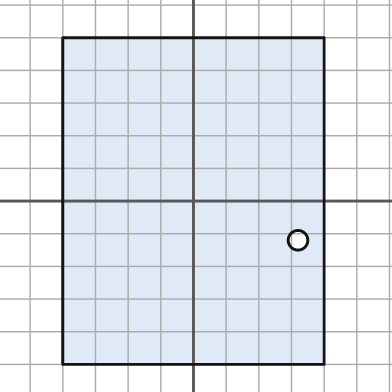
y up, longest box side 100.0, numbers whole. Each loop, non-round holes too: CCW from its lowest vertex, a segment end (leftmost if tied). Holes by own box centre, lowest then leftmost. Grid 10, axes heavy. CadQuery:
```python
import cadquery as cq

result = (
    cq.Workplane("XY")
    .moveTo(-40.0, -50.0)
    .lineTo(40.0, -50.0)
    .lineTo(40.0, 50.0)
    .lineTo(-40.0, 50.0)
    .close()
    .moveTo(32.0, -12.0)
    .circle(3.0)
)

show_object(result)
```